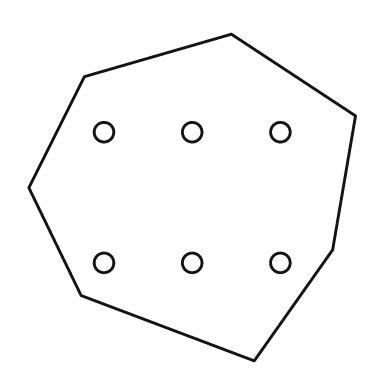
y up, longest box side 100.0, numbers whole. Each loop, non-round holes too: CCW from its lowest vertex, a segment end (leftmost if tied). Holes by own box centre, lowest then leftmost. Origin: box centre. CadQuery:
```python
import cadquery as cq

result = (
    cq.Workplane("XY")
    .moveTo(19.0, -50.0)
    .lineTo(43.0, -16.0)
    .lineTo(50.0, 25.0)
    .lineTo(12.0, 50.0)
    .lineTo(-33.0, 37.0)
    .lineTo(-50.0, 3.0)
    .lineTo(-34.0, -30.0)
    .close()
    .moveTo(-27.0, -20.0)
    .circle(3.0)
    .moveTo(0.0, -20.0)
    .circle(3.0)
    .moveTo(27.0, -20.0)
    .circle(3.0)
    .moveTo(-27.0, 20.0)
    .circle(3.0)
    .moveTo(0.0, 20.0)
    .circle(3.0)
    .moveTo(27.0, 20.0)
    .circle(3.0)
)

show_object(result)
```